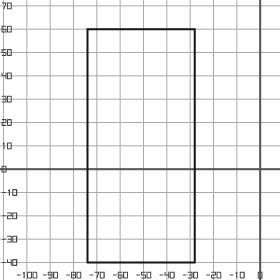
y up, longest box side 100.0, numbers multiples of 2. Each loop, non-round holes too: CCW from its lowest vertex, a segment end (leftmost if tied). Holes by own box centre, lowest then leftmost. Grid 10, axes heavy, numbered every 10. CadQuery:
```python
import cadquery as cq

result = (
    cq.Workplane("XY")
    .moveTo(-74.0, -40.0)
    .lineTo(-28.0, -40.0)
    .lineTo(-28.0, 60.0)
    .lineTo(-74.0, 60.0)
    .close()
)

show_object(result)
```